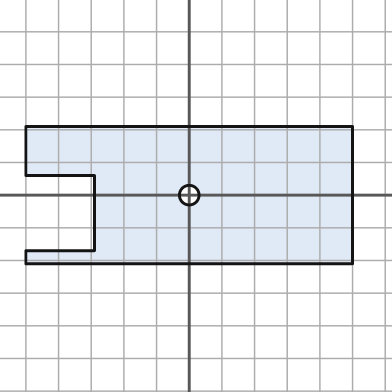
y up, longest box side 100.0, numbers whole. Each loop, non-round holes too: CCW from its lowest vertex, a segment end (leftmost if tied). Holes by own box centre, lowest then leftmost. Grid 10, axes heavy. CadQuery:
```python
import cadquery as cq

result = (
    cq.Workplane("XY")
    .moveTo(-50.0, -21.0)
    .lineTo(50.0, -21.0)
    .lineTo(50.0, 21.0)
    .lineTo(-50.0, 21.0)
    .lineTo(-50.0, 6.0)
    .lineTo(-29.0, 6.0)
    .lineTo(-29.0, -17.0)
    .lineTo(-50.0, -17.0)
    .close()
    .moveTo(0.0, 0.0)
    .circle(3.0)
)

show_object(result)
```